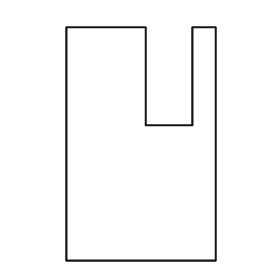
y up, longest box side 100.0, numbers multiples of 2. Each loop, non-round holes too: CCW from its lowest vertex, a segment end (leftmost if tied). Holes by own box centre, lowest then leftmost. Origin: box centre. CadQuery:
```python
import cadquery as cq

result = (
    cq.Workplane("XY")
    .moveTo(-32.0, -50.0)
    .lineTo(32.0, -50.0)
    .lineTo(32.0, 50.0)
    .lineTo(22.0, 50.0)
    .lineTo(22.0, 8.0)
    .lineTo(2.0, 8.0)
    .lineTo(2.0, 50.0)
    .lineTo(-32.0, 50.0)
    .close()
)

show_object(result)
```